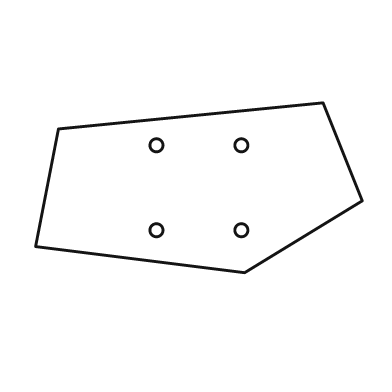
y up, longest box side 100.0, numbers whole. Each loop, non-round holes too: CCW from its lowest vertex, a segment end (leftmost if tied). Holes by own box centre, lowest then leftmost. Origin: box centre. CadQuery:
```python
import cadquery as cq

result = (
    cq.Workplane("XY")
    .moveTo(14.0, -26.0)
    .lineTo(50.0, -4.0)
    .lineTo(38.0, 26.0)
    .lineTo(-43.0, 18.0)
    .lineTo(-50.0, -18.0)
    .close()
    .moveTo(-13.0, -13.0)
    .circle(2.0)
    .moveTo(13.0, -13.0)
    .circle(2.0)
    .moveTo(-13.0, 13.0)
    .circle(2.0)
    .moveTo(13.0, 13.0)
    .circle(2.0)
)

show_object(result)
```